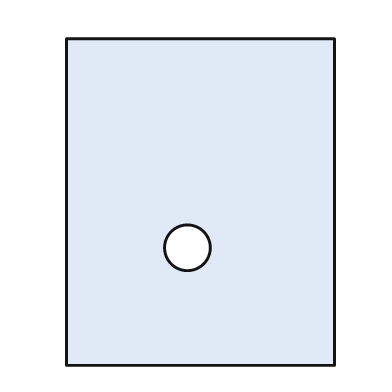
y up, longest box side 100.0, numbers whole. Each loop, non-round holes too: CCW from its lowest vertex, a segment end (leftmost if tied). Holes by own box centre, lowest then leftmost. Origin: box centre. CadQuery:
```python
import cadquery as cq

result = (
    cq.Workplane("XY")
    .moveTo(-41.0, -50.0)
    .lineTo(41.0, -50.0)
    .lineTo(41.0, 50.0)
    .lineTo(-41.0, 50.0)
    .close()
    .moveTo(-4.0, -14.0)
    .circle(7.0)
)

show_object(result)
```